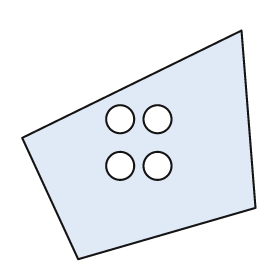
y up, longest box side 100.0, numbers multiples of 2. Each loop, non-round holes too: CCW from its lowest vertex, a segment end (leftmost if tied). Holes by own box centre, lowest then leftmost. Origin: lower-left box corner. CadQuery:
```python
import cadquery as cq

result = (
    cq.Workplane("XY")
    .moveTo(24.0, 0.0)
    .lineTo(100.0, 22.0)
    .lineTo(94.0, 98.0)
    .lineTo(0.0, 52.0)
    .close()
    .moveTo(42.0, 40.0)
    .circle(6.0)
    .moveTo(58.0, 40.0)
    .circle(6.0)
    .moveTo(42.0, 60.0)
    .circle(6.0)
    .moveTo(58.0, 60.0)
    .circle(6.0)
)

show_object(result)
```